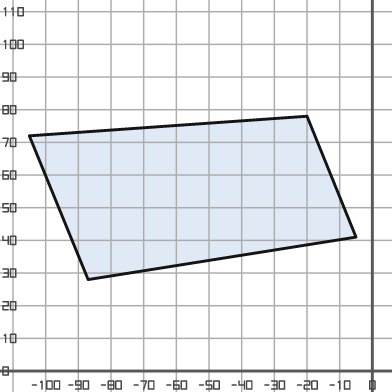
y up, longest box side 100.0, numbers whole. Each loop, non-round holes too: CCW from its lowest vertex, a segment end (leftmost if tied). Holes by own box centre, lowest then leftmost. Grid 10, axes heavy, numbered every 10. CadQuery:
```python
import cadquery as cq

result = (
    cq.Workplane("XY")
    .moveTo(-87.0, 28.0)
    .lineTo(-5.0, 41.0)
    .lineTo(-20.0, 78.0)
    .lineTo(-105.0, 72.0)
    .close()
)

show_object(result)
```